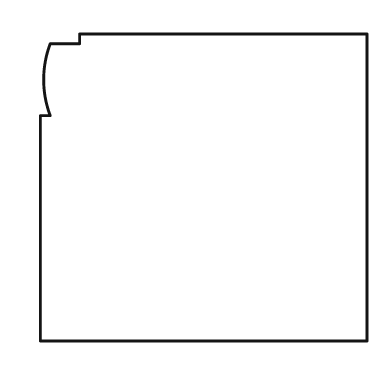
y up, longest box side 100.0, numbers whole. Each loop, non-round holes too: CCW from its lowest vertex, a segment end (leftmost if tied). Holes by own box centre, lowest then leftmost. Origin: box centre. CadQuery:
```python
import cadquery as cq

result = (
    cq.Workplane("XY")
    .moveTo(-50.0, -47.0)
    .lineTo(50.0, -47.0)
    .lineTo(50.0, 47.0)
    .lineTo(-38.0, 47.0)
    .lineTo(-38.0, 44.0)
    .lineTo(-47.0, 44.0)
    .threePointArc((-49.0, 33.0), (-47.0, 22.0))
    .lineTo(-50.0, 22.0)
    .close()
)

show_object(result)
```